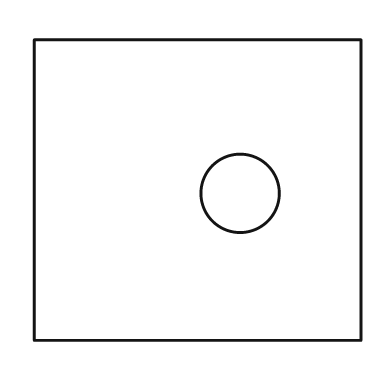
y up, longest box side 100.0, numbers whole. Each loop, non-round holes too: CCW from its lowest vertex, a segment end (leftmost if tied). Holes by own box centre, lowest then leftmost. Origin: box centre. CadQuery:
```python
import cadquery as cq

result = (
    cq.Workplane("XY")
    .moveTo(-50.0, -46.0)
    .lineTo(50.0, -46.0)
    .lineTo(50.0, 46.0)
    .lineTo(-50.0, 46.0)
    .close()
    .moveTo(13.0, -1.0)
    .circle(12.0)
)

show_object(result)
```